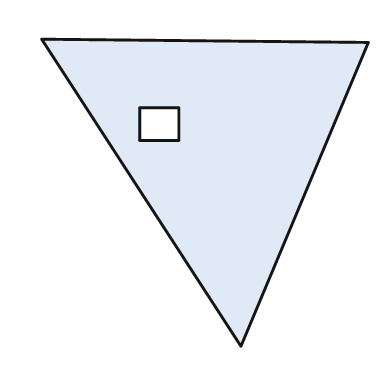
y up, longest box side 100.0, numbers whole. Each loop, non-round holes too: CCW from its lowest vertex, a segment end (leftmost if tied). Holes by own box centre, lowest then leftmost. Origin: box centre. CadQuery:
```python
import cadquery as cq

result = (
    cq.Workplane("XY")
    .moveTo(11.0, -47.0)
    .lineTo(50.0, 46.0)
    .lineTo(-50.0, 47.0)
    .close()
    .moveTo(-20.0, 16.0)
    .lineTo(-8.0, 16.0)
    .lineTo(-8.0, 26.0)
    .lineTo(-20.0, 26.0)
    .close()
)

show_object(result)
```